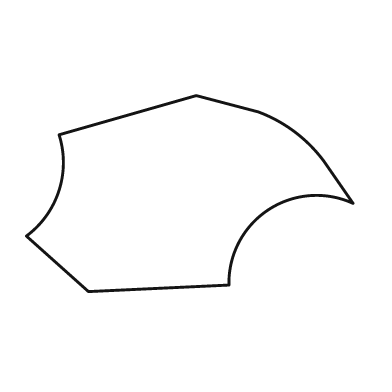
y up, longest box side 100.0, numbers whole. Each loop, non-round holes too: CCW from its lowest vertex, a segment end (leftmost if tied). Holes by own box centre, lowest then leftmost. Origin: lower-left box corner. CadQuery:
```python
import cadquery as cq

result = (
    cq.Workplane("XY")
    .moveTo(19.0, 0.0)
    .lineTo(62.0, 2.0)
    .threePointArc((74.0, 25.0), (100.0, 27.0))
    .lineTo(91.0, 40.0)
    .threePointArc((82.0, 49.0), (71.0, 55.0))
    .lineTo(52.0, 60.0)
    .lineTo(10.0, 48.0)
    .threePointArc((10.0, 31.0), (0.0, 17.0))
    .close()
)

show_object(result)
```